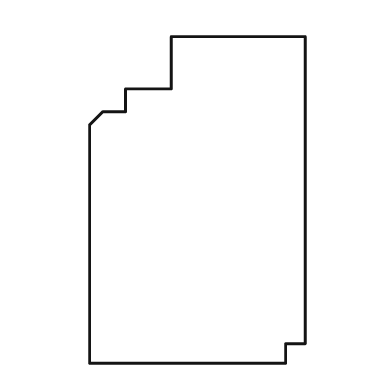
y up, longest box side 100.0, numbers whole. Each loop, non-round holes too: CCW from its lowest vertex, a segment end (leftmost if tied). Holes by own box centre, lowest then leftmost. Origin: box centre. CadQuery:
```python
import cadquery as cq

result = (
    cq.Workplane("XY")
    .moveTo(-33.0, -50.0)
    .lineTo(27.0, -50.0)
    .lineTo(27.0, -44.0)
    .lineTo(33.0, -44.0)
    .lineTo(33.0, 50.0)
    .lineTo(-8.0, 50.0)
    .lineTo(-8.0, 34.0)
    .lineTo(-22.0, 34.0)
    .lineTo(-22.0, 27.0)
    .lineTo(-29.0, 27.0)
    .lineTo(-33.0, 23.0)
    .close()
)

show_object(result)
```